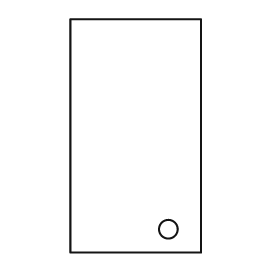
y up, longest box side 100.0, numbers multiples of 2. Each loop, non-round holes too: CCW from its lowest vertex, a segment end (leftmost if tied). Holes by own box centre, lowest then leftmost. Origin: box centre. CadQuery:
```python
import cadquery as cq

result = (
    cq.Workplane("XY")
    .moveTo(-28.0, -50.0)
    .lineTo(28.0, -50.0)
    .lineTo(28.0, 50.0)
    .lineTo(-28.0, 50.0)
    .close()
    .moveTo(14.0, -40.0)
    .circle(4.0)
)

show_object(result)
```